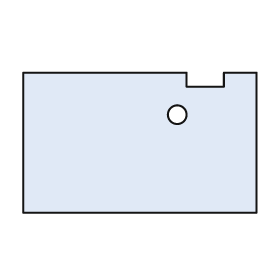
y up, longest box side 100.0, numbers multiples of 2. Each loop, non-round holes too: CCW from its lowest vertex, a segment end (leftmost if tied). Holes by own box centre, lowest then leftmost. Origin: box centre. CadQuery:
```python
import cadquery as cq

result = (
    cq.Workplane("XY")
    .moveTo(-50.0, -30.0)
    .lineTo(50.0, -30.0)
    .lineTo(50.0, 30.0)
    .lineTo(36.0, 30.0)
    .lineTo(36.0, 24.0)
    .lineTo(20.0, 24.0)
    .lineTo(20.0, 30.0)
    .lineTo(-50.0, 30.0)
    .close()
    .moveTo(16.0, 12.0)
    .circle(4.0)
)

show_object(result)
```